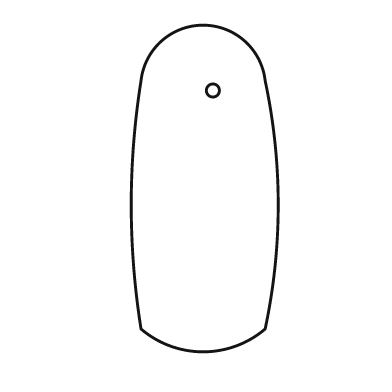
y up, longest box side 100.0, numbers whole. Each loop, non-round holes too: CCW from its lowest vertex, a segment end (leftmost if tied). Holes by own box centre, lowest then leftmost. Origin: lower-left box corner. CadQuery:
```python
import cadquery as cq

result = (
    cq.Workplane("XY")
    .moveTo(3.0, 7.0)
    .threePointArc((22.0, 0.0), (41.0, 7.0))
    .threePointArc((45.0, 45.0), (41.0, 83.0))
    .threePointArc((22.0, 100.0), (3.0, 83.0))
    .threePointArc((0.0, 45.0), (3.0, 7.0))
    .close()
    .moveTo(25.0, 80.0)
    .circle(2.0)
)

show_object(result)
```